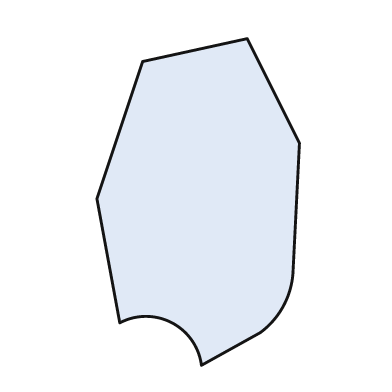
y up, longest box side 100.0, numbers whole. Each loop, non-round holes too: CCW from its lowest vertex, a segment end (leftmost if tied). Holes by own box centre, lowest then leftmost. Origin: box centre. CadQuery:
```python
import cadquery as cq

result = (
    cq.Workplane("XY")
    .moveTo(1.0, -50.0)
    .lineTo(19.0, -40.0)
    .threePointArc((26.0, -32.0), (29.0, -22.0))
    .lineTo(31.0, 18.0)
    .lineTo(15.0, 50.0)
    .lineTo(-17.0, 43.0)
    .lineTo(-31.0, 1.0)
    .lineTo(-24.0, -37.0)
    .threePointArc((-8.0, -37.0), (1.0, -50.0))
    .close()
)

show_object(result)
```